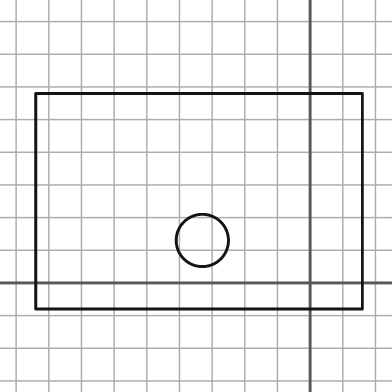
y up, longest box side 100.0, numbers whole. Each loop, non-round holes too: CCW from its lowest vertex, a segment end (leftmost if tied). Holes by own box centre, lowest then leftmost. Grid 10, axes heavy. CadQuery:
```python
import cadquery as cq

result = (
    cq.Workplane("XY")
    .moveTo(-84.0, -8.0)
    .lineTo(16.0, -8.0)
    .lineTo(16.0, 58.0)
    .lineTo(-84.0, 58.0)
    .close()
    .moveTo(-33.0, 13.0)
    .circle(8.0)
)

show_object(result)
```